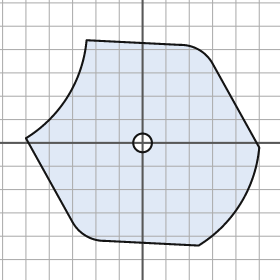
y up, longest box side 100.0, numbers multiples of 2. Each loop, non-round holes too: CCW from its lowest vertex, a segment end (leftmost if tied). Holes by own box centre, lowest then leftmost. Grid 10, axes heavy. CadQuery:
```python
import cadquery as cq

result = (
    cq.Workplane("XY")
    .moveTo(24.0, -44.0)
    .threePointArc((42.0, -26.0), (50.0, -2.0))
    .lineTo(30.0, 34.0)
    .threePointArc((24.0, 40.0), (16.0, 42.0))
    .lineTo(-24.0, 44.0)
    .threePointArc((-32.0, 20.0), (-50.0, 2.0))
    .lineTo(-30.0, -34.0)
    .threePointArc((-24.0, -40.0), (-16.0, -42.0))
    .close()
    .moveTo(0.0, 0.0)
    .circle(4.0)
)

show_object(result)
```